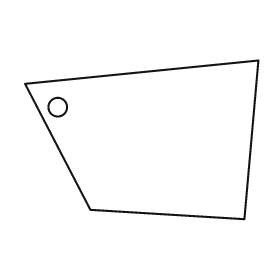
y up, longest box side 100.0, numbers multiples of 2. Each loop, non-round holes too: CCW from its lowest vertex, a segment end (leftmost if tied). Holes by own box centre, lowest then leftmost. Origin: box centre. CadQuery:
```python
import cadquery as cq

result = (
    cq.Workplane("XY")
    .moveTo(44.0, -34.0)
    .lineTo(50.0, 34.0)
    .lineTo(-50.0, 24.0)
    .lineTo(-22.0, -30.0)
    .close()
    .moveTo(-36.0, 14.0)
    .circle(4.0)
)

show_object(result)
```